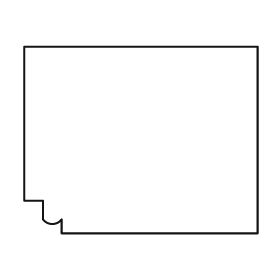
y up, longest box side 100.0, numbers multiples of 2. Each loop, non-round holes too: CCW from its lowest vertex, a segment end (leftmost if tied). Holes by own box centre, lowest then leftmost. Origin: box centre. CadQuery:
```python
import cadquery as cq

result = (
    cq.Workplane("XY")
    .moveTo(-34.0, -40.0)
    .lineTo(50.0, -40.0)
    .lineTo(50.0, 40.0)
    .lineTo(-50.0, 40.0)
    .lineTo(-50.0, -26.0)
    .lineTo(-42.0, -26.0)
    .lineTo(-42.0, -34.0)
    .threePointArc((-38.0, -36.0), (-34.0, -34.0))
    .close()
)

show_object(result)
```